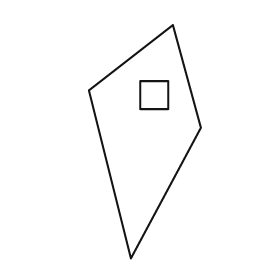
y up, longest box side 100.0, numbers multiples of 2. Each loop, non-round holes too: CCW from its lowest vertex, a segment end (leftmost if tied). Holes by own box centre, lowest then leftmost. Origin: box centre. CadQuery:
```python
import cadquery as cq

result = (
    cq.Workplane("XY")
    .moveTo(-6.0, -50.0)
    .lineTo(24.0, 6.0)
    .lineTo(12.0, 50.0)
    .lineTo(-24.0, 22.0)
    .close()
    .moveTo(-2.0, 14.0)
    .lineTo(10.0, 14.0)
    .lineTo(10.0, 26.0)
    .lineTo(-2.0, 26.0)
    .close()
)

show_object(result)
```